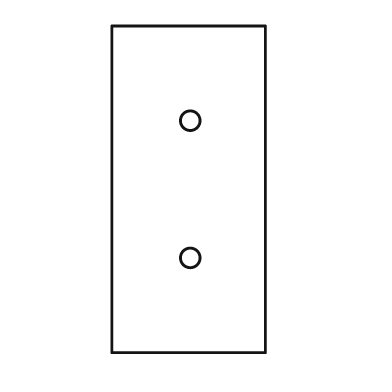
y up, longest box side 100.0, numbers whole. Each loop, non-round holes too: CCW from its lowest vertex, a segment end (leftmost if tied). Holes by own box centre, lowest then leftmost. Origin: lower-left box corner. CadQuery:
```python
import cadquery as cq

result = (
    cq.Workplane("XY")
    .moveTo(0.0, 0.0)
    .lineTo(47.0, 0.0)
    .lineTo(47.0, 100.0)
    .lineTo(0.0, 100.0)
    .close()
    .moveTo(24.0, 29.0)
    .circle(3.0)
    .moveTo(24.0, 71.0)
    .circle(3.0)
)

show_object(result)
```